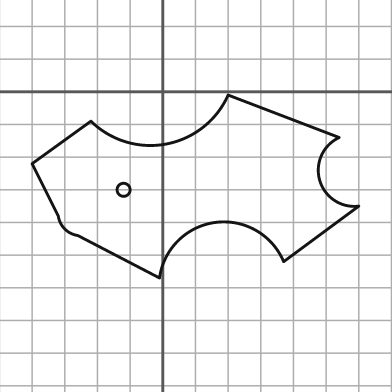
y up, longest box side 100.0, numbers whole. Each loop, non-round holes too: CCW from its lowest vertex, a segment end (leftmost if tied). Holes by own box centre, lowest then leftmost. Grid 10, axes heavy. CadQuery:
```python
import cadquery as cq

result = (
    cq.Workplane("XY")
    .moveTo(-1.0, -57.0)
    .threePointArc((16.0, -40.0), (37.0, -52.0))
    .lineTo(60.0, -35.0)
    .threePointArc((48.0, -27.0), (54.0, -14.0))
    .lineTo(20.0, -1.0)
    .threePointArc((1.0, -16.0), (-22.0, -9.0))
    .lineTo(-40.0, -22.0)
    .lineTo(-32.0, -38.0)
    .threePointArc((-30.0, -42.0), (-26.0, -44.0))
    .close()
    .moveTo(-12.0, -30.0)
    .circle(2.0)
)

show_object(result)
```